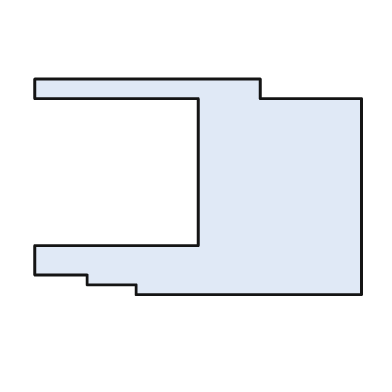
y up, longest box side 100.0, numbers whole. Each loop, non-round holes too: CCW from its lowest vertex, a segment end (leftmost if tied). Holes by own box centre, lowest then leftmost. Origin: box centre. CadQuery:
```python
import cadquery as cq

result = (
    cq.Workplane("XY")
    .moveTo(-19.0, -33.0)
    .lineTo(50.0, -33.0)
    .lineTo(50.0, 27.0)
    .lineTo(19.0, 27.0)
    .lineTo(19.0, 33.0)
    .lineTo(-50.0, 33.0)
    .lineTo(-50.0, 27.0)
    .lineTo(0.0, 27.0)
    .lineTo(0.0, -18.0)
    .lineTo(-50.0, -18.0)
    .lineTo(-50.0, -27.0)
    .lineTo(-34.0, -27.0)
    .lineTo(-34.0, -30.0)
    .lineTo(-19.0, -30.0)
    .close()
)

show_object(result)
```